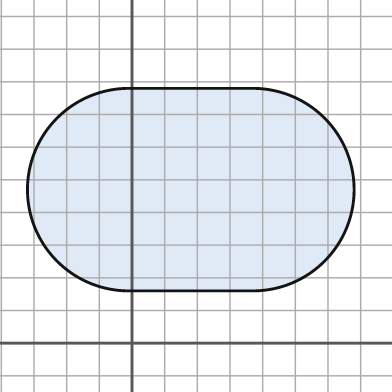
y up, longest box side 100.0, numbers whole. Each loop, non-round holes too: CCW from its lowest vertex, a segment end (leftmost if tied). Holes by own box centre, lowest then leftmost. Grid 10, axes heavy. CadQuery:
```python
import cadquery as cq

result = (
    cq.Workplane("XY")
    .moveTo(-1.0, 16.0)
    .lineTo(37.0, 16.0)
    .threePointArc((68.0, 47.0), (37.0, 78.0))
    .lineTo(-1.0, 78.0)
    .threePointArc((-32.0, 47.0), (-1.0, 16.0))
    .close()
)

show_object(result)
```